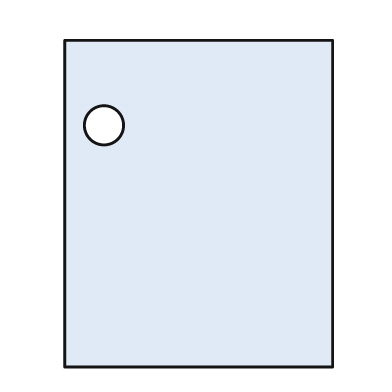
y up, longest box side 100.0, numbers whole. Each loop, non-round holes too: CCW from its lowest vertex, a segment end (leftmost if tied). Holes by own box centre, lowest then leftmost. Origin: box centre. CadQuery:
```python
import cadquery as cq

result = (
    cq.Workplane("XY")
    .moveTo(-41.0, -50.0)
    .lineTo(41.0, -50.0)
    .lineTo(41.0, 50.0)
    .lineTo(-41.0, 50.0)
    .close()
    .moveTo(-29.0, 24.0)
    .circle(6.0)
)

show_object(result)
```